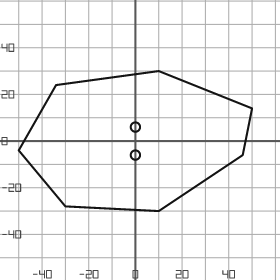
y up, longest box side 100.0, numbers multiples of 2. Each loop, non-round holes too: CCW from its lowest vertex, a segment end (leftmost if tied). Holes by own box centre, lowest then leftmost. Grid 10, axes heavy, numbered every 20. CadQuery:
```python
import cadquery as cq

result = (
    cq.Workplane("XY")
    .moveTo(10.0, -30.0)
    .lineTo(46.0, -6.0)
    .lineTo(50.0, 14.0)
    .lineTo(10.0, 30.0)
    .lineTo(-34.0, 24.0)
    .lineTo(-50.0, -4.0)
    .lineTo(-30.0, -28.0)
    .close()
    .moveTo(0.0, -6.0)
    .circle(2.0)
    .moveTo(0.0, 6.0)
    .circle(2.0)
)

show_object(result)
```